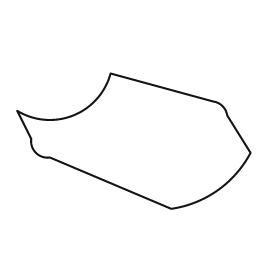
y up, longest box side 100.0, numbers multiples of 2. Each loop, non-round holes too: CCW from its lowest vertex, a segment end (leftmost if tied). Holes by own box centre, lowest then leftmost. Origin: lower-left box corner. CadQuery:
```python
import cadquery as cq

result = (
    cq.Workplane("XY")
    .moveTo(66.0, 0.0)
    .threePointArc((86.0, 8.0), (100.0, 24.0))
    .lineTo(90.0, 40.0)
    .threePointArc((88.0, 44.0), (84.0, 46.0))
    .lineTo(40.0, 58.0)
    .threePointArc((24.0, 40.0), (0.0, 42.0))
    .lineTo(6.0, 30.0)
    .threePointArc((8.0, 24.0), (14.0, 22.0))
    .close()
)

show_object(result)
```